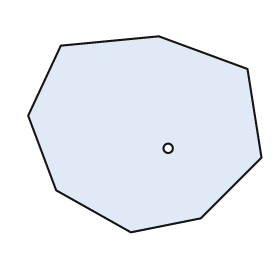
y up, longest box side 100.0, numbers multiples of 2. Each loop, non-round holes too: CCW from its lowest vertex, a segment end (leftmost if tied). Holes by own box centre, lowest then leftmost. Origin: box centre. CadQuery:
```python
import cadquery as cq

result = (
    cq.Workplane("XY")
    .moveTo(-6.0, -42.0)
    .lineTo(24.0, -36.0)
    .lineTo(50.0, -10.0)
    .lineTo(44.0, 28.0)
    .lineTo(6.0, 42.0)
    .lineTo(-36.0, 38.0)
    .lineTo(-50.0, 8.0)
    .lineTo(-38.0, -24.0)
    .close()
    .moveTo(10.0, -6.0)
    .circle(2.0)
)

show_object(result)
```